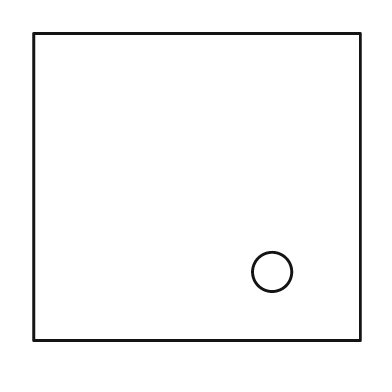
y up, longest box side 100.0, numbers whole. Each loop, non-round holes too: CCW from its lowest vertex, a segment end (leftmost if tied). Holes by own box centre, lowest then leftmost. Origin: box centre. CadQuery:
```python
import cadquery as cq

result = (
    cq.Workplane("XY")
    .moveTo(-50.0, -47.0)
    .lineTo(50.0, -47.0)
    .lineTo(50.0, 47.0)
    .lineTo(-50.0, 47.0)
    .close()
    .moveTo(23.0, -26.0)
    .circle(6.0)
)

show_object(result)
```